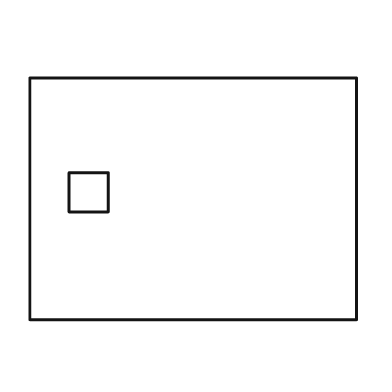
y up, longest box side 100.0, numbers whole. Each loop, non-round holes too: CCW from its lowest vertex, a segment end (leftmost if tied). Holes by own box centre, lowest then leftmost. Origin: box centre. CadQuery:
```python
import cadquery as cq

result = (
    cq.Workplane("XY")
    .moveTo(-50.0, -37.0)
    .lineTo(50.0, -37.0)
    .lineTo(50.0, 37.0)
    .lineTo(-50.0, 37.0)
    .close()
    .moveTo(-38.0, -4.0)
    .lineTo(-26.0, -4.0)
    .lineTo(-26.0, 8.0)
    .lineTo(-38.0, 8.0)
    .close()
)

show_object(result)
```